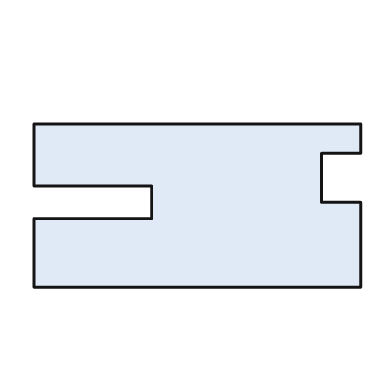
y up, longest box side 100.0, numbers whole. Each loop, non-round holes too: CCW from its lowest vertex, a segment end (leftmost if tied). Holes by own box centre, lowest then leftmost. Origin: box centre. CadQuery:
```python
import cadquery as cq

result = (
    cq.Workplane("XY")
    .moveTo(-50.0, -25.0)
    .lineTo(50.0, -25.0)
    .lineTo(50.0, 1.0)
    .lineTo(38.0, 1.0)
    .lineTo(38.0, 16.0)
    .lineTo(50.0, 16.0)
    .lineTo(50.0, 25.0)
    .lineTo(-50.0, 25.0)
    .lineTo(-50.0, 6.0)
    .lineTo(-14.0, 6.0)
    .lineTo(-14.0, -4.0)
    .lineTo(-50.0, -4.0)
    .close()
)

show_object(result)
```